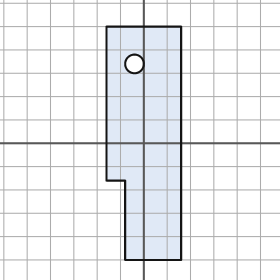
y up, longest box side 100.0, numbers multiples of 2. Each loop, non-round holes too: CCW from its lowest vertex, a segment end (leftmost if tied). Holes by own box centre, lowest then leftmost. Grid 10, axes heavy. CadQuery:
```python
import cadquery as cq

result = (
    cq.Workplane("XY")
    .moveTo(-8.0, -50.0)
    .lineTo(16.0, -50.0)
    .lineTo(16.0, 50.0)
    .lineTo(-16.0, 50.0)
    .lineTo(-16.0, -16.0)
    .lineTo(-8.0, -16.0)
    .close()
    .moveTo(-4.0, 34.0)
    .circle(4.0)
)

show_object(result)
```